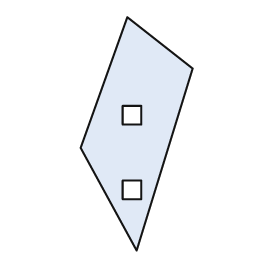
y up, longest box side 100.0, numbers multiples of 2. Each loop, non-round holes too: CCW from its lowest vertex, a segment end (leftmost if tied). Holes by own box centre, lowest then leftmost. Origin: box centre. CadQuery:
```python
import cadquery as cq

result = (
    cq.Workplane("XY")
    .moveTo(0.0, -50.0)
    .lineTo(24.0, 28.0)
    .lineTo(-4.0, 50.0)
    .lineTo(-24.0, -6.0)
    .close()
    .moveTo(-6.0, -28.0)
    .lineTo(2.0, -28.0)
    .lineTo(2.0, -20.0)
    .lineTo(-6.0, -20.0)
    .close()
    .moveTo(-6.0, 4.0)
    .lineTo(2.0, 4.0)
    .lineTo(2.0, 12.0)
    .lineTo(-6.0, 12.0)
    .close()
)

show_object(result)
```